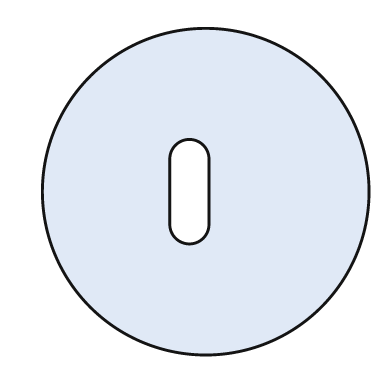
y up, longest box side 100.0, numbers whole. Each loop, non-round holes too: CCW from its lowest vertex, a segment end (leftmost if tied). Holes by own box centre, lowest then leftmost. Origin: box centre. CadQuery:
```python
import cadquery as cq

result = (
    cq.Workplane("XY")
    .moveTo(0.0, 0.0)
    .circle(50.0)
    .moveTo(-11.0, -10.0)
    .threePointArc((-5.0, -16.0), (1.0, -10.0))
    .lineTo(1.0, 10.0)
    .threePointArc((-5.0, 16.0), (-11.0, 10.0))
    .close()
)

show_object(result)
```